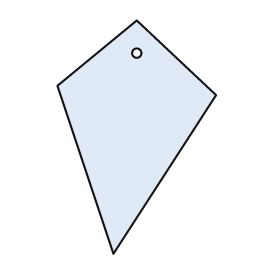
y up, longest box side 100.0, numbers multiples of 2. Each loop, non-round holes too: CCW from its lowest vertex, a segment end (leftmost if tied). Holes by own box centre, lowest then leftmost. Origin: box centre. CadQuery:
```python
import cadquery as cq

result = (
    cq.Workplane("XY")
    .moveTo(-10.0, -50.0)
    .lineTo(34.0, 18.0)
    .lineTo(0.0, 50.0)
    .lineTo(-34.0, 22.0)
    .close()
    .moveTo(0.0, 36.0)
    .circle(2.0)
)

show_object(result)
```